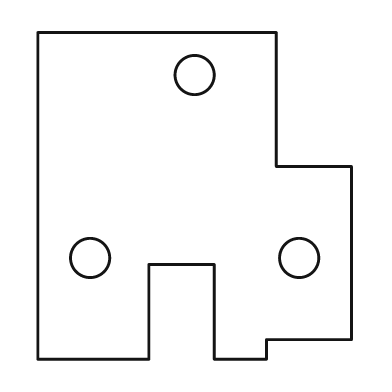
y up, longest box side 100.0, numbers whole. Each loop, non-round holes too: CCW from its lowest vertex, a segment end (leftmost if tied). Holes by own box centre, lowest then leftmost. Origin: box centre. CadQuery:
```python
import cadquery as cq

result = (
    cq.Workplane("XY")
    .moveTo(-48.0, -50.0)
    .lineTo(-14.0, -50.0)
    .lineTo(-14.0, -21.0)
    .lineTo(6.0, -21.0)
    .lineTo(6.0, -50.0)
    .lineTo(22.0, -50.0)
    .lineTo(22.0, -44.0)
    .lineTo(48.0, -44.0)
    .lineTo(48.0, 9.0)
    .lineTo(25.0, 9.0)
    .lineTo(25.0, 50.0)
    .lineTo(-48.0, 50.0)
    .close()
    .moveTo(-32.0, -19.0)
    .circle(6.0)
    .moveTo(32.0, -19.0)
    .circle(6.0)
    .moveTo(0.0, 37.0)
    .circle(6.0)
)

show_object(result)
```